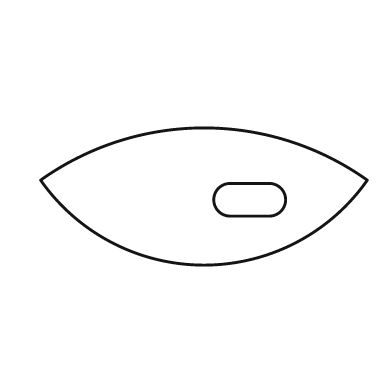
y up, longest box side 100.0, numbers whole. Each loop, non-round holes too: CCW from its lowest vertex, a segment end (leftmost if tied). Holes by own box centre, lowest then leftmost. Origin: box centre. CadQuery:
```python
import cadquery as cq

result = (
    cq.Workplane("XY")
    .moveTo(-50.0, 5.0)
    .threePointArc((0.0, -21.0), (50.0, 5.0))
    .threePointArc((0.0, 21.0), (-50.0, 5.0))
    .close()
    .moveTo(8.0, -6.0)
    .lineTo(20.0, -6.0)
    .threePointArc((25.0, -1.0), (20.0, 4.0))
    .lineTo(8.0, 4.0)
    .threePointArc((3.0, -1.0), (8.0, -6.0))
    .close()
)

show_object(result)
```